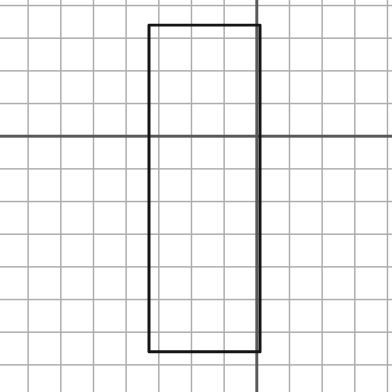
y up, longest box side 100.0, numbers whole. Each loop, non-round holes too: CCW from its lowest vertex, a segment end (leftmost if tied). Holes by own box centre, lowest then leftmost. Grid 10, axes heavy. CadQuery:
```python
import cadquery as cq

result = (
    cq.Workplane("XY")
    .moveTo(-33.0, -66.0)
    .lineTo(1.0, -66.0)
    .lineTo(1.0, 34.0)
    .lineTo(-33.0, 34.0)
    .close()
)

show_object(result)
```